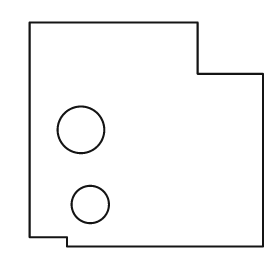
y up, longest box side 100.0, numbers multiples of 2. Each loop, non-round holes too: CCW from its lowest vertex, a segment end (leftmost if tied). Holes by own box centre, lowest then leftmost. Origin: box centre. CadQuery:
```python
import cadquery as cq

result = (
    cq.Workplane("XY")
    .moveTo(-34.0, -48.0)
    .lineTo(50.0, -48.0)
    .lineTo(50.0, 26.0)
    .lineTo(22.0, 26.0)
    .lineTo(22.0, 48.0)
    .lineTo(-50.0, 48.0)
    .lineTo(-50.0, -44.0)
    .lineTo(-34.0, -44.0)
    .close()
    .moveTo(-24.0, -30.0)
    .circle(8.0)
    .moveTo(-28.0, 2.0)
    .circle(10.0)
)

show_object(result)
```